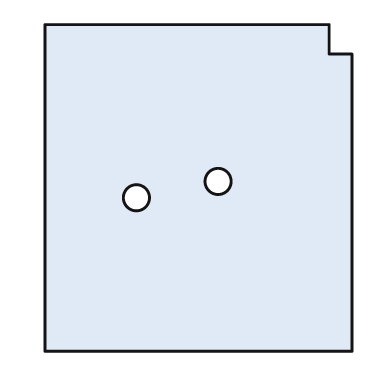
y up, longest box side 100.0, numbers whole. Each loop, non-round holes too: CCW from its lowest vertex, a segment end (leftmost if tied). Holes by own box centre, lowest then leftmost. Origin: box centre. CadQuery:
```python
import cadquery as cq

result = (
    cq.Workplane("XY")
    .moveTo(-47.0, -50.0)
    .lineTo(47.0, -50.0)
    .lineTo(47.0, 41.0)
    .lineTo(40.0, 41.0)
    .lineTo(40.0, 50.0)
    .lineTo(-47.0, 50.0)
    .close()
    .moveTo(-19.0, -3.0)
    .circle(4.0)
    .moveTo(6.0, 2.0)
    .circle(4.0)
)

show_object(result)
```